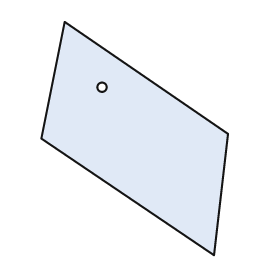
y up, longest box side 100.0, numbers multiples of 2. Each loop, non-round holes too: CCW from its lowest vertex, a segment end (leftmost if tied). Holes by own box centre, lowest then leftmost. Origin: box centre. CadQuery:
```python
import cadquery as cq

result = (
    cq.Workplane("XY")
    .moveTo(34.0, -50.0)
    .lineTo(40.0, 2.0)
    .lineTo(-30.0, 50.0)
    .lineTo(-40.0, 0.0)
    .close()
    .moveTo(-14.0, 22.0)
    .circle(2.0)
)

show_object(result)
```